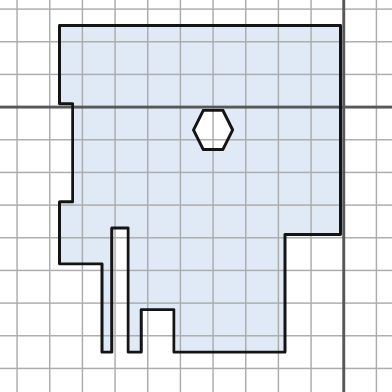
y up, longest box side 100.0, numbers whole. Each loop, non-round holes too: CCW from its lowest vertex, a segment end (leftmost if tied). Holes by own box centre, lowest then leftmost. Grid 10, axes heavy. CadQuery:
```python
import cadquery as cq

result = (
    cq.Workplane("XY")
    .moveTo(-74.0, -75.0)
    .lineTo(-71.0, -75.0)
    .lineTo(-71.0, -37.0)
    .lineTo(-66.0, -37.0)
    .lineTo(-66.0, -75.0)
    .lineTo(-62.0, -75.0)
    .lineTo(-62.0, -62.0)
    .lineTo(-52.0, -62.0)
    .lineTo(-52.0, -75.0)
    .lineTo(-18.0, -75.0)
    .lineTo(-18.0, -39.0)
    .lineTo(-1.0, -39.0)
    .lineTo(-1.0, 25.0)
    .lineTo(-87.0, 25.0)
    .lineTo(-87.0, 1.0)
    .lineTo(-83.0, 1.0)
    .lineTo(-83.0, -29.0)
    .lineTo(-87.0, -29.0)
    .lineTo(-87.0, -48.0)
    .lineTo(-74.0, -48.0)
    .close()
    .moveTo(-43.0, -13.0)
    .lineTo(-37.0, -13.0)
    .lineTo(-34.0, -7.0)
    .lineTo(-37.0, -1.0)
    .lineTo(-43.0, -1.0)
    .lineTo(-46.0, -7.0)
    .close()
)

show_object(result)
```